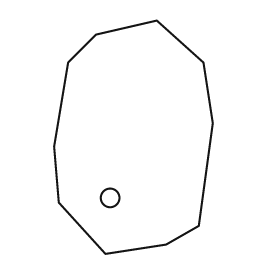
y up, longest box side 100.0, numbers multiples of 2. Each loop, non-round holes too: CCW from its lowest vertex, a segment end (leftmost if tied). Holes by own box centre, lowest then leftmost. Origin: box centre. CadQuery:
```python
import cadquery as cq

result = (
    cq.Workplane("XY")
    .moveTo(-12.0, -50.0)
    .lineTo(14.0, -46.0)
    .lineTo(28.0, -38.0)
    .lineTo(34.0, 6.0)
    .lineTo(30.0, 32.0)
    .lineTo(10.0, 50.0)
    .lineTo(-16.0, 44.0)
    .lineTo(-28.0, 32.0)
    .lineTo(-34.0, -4.0)
    .lineTo(-32.0, -28.0)
    .close()
    .moveTo(-10.0, -26.0)
    .circle(4.0)
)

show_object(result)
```